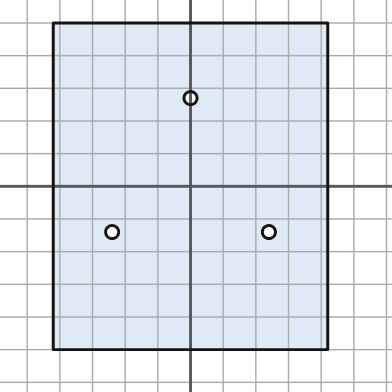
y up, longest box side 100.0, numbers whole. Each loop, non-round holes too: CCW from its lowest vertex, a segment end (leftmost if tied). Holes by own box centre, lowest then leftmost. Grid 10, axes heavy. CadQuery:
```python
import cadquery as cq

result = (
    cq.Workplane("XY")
    .moveTo(-42.0, -50.0)
    .lineTo(42.0, -50.0)
    .lineTo(42.0, 50.0)
    .lineTo(-42.0, 50.0)
    .close()
    .moveTo(-24.0, -14.0)
    .circle(2.0)
    .moveTo(24.0, -14.0)
    .circle(2.0)
    .moveTo(0.0, 27.0)
    .circle(2.0)
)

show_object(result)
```